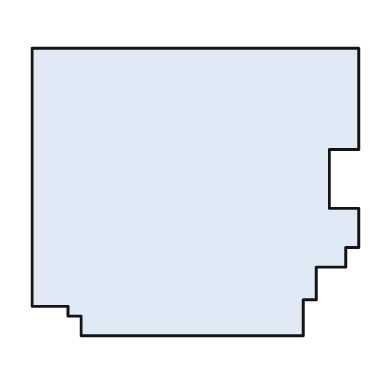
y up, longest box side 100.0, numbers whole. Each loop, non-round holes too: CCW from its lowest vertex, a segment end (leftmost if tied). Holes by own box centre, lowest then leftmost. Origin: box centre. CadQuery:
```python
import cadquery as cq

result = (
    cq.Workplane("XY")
    .moveTo(-35.0, -44.0)
    .lineTo(33.0, -44.0)
    .lineTo(33.0, -33.0)
    .lineTo(37.0, -33.0)
    .lineTo(37.0, -23.0)
    .lineTo(46.0, -23.0)
    .lineTo(46.0, -17.0)
    .lineTo(50.0, -17.0)
    .lineTo(50.0, -5.0)
    .lineTo(41.0, -5.0)
    .lineTo(41.0, 13.0)
    .lineTo(50.0, 13.0)
    .lineTo(50.0, 44.0)
    .lineTo(-50.0, 44.0)
    .lineTo(-50.0, -35.0)
    .lineTo(-39.0, -35.0)
    .lineTo(-39.0, -38.0)
    .lineTo(-35.0, -38.0)
    .close()
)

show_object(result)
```